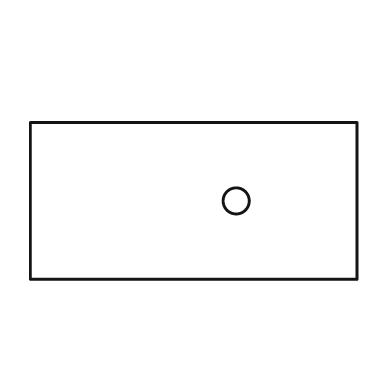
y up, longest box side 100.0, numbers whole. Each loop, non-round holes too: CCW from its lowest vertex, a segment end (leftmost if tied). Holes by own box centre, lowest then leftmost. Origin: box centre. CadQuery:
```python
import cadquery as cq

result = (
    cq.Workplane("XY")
    .moveTo(-50.0, -24.0)
    .lineTo(50.0, -24.0)
    .lineTo(50.0, 24.0)
    .lineTo(-50.0, 24.0)
    .close()
    .moveTo(13.0, 0.0)
    .circle(4.0)
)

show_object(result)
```